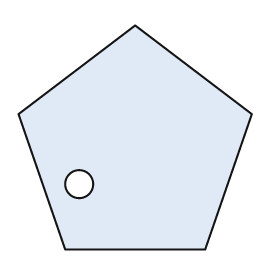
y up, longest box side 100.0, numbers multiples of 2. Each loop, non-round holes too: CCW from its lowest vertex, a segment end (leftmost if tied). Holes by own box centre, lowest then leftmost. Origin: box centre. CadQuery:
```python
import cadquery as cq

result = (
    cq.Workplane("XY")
    .moveTo(-30.0, -48.0)
    .lineTo(30.0, -48.0)
    .lineTo(50.0, 10.0)
    .lineTo(0.0, 48.0)
    .lineTo(-50.0, 10.0)
    .close()
    .moveTo(-24.0, -20.0)
    .circle(6.0)
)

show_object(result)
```